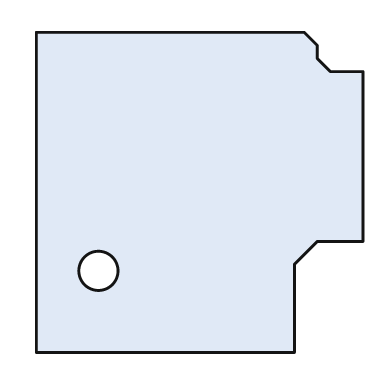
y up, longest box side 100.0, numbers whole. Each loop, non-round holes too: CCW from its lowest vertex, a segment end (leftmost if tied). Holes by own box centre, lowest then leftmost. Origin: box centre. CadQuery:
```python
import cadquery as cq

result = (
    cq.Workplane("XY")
    .moveTo(-50.0, -49.0)
    .lineTo(29.0, -49.0)
    .lineTo(29.0, -22.0)
    .lineTo(36.0, -15.0)
    .lineTo(50.0, -15.0)
    .lineTo(50.0, 37.0)
    .lineTo(40.0, 37.0)
    .lineTo(36.0, 41.0)
    .lineTo(36.0, 45.0)
    .lineTo(32.0, 49.0)
    .lineTo(-50.0, 49.0)
    .close()
    .moveTo(-31.0, -24.0)
    .circle(6.0)
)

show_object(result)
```